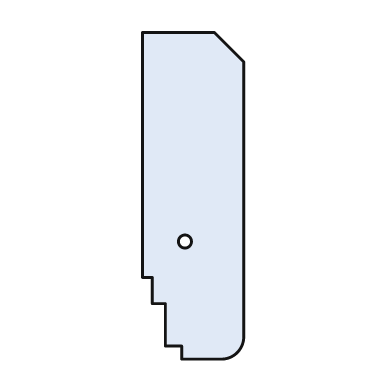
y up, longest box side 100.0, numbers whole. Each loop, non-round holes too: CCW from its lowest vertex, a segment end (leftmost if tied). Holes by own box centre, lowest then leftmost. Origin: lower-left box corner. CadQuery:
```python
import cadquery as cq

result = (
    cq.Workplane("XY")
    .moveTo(12.0, 0.0)
    .lineTo(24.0, 0.0)
    .threePointArc((29.0, 2.0), (31.0, 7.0))
    .lineTo(31.0, 91.0)
    .lineTo(22.0, 100.0)
    .lineTo(0.0, 100.0)
    .lineTo(0.0, 25.0)
    .lineTo(3.0, 25.0)
    .lineTo(3.0, 17.0)
    .lineTo(7.0, 17.0)
    .lineTo(7.0, 4.0)
    .lineTo(12.0, 4.0)
    .close()
    .moveTo(13.0, 36.0)
    .circle(2.0)
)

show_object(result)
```